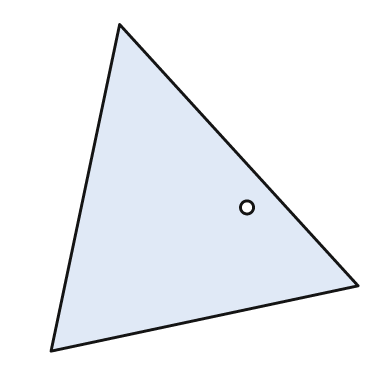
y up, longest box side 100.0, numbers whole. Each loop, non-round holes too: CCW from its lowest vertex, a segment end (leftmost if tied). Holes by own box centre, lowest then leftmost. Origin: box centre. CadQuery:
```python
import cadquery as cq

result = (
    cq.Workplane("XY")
    .moveTo(-47.0, -50.0)
    .lineTo(47.0, -30.0)
    .lineTo(-26.0, 50.0)
    .close()
    .moveTo(13.0, -6.0)
    .circle(2.0)
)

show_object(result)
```